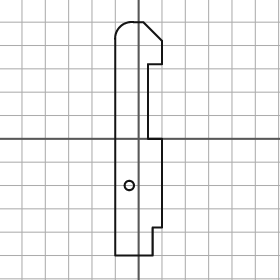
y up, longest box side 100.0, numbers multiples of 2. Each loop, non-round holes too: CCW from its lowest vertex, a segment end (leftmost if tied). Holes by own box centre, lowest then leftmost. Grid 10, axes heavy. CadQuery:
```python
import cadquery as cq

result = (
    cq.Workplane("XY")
    .moveTo(-10.0, -50.0)
    .lineTo(6.0, -50.0)
    .lineTo(6.0, -38.0)
    .lineTo(10.0, -38.0)
    .lineTo(10.0, 0.0)
    .lineTo(4.0, 0.0)
    .lineTo(4.0, 32.0)
    .lineTo(10.0, 32.0)
    .lineTo(10.0, 42.0)
    .lineTo(2.0, 50.0)
    .lineTo(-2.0, 50.0)
    .threePointArc((-8.0, 48.0), (-10.0, 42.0))
    .close()
    .moveTo(-4.0, -20.0)
    .circle(2.0)
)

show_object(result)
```